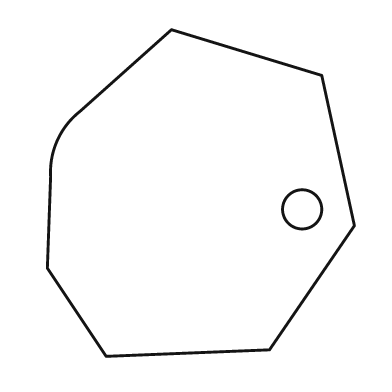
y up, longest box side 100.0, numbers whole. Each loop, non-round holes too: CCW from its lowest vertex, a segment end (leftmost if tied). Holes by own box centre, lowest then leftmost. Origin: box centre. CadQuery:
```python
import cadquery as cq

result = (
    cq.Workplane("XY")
    .moveTo(-29.0, -50.0)
    .lineTo(21.0, -48.0)
    .lineTo(47.0, -10.0)
    .lineTo(37.0, 36.0)
    .lineTo(-9.0, 50.0)
    .lineTo(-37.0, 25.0)
    .threePointArc((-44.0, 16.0), (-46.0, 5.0))
    .lineTo(-47.0, -23.0)
    .close()
    .moveTo(31.0, -5.0)
    .circle(6.0)
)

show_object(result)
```